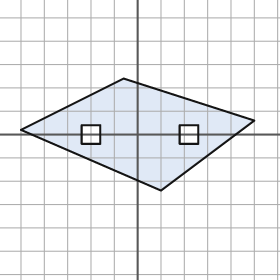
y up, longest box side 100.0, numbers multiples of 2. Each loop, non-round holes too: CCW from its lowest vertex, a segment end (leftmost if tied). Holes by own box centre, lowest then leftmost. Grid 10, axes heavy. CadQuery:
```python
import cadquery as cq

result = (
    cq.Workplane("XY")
    .moveTo(10.0, -24.0)
    .lineTo(50.0, 6.0)
    .lineTo(-6.0, 24.0)
    .lineTo(-50.0, 2.0)
    .close()
    .moveTo(-24.0, -4.0)
    .lineTo(-16.0, -4.0)
    .lineTo(-16.0, 4.0)
    .lineTo(-24.0, 4.0)
    .close()
    .moveTo(18.0, -4.0)
    .lineTo(26.0, -4.0)
    .lineTo(26.0, 4.0)
    .lineTo(18.0, 4.0)
    .close()
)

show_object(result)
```